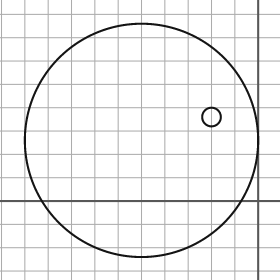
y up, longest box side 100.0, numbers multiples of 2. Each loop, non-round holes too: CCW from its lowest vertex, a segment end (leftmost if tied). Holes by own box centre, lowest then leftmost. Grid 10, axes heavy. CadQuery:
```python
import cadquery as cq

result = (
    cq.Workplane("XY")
    .moveTo(-50.0, 26.0)
    .circle(50.0)
    .moveTo(-20.0, 36.0)
    .circle(4.0)
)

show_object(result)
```